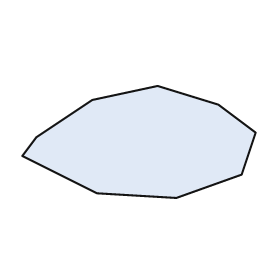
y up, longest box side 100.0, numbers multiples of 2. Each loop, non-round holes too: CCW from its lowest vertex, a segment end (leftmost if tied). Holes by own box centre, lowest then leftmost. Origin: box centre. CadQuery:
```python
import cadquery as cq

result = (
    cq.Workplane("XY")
    .moveTo(16.0, -24.0)
    .lineTo(44.0, -14.0)
    .lineTo(50.0, 4.0)
    .lineTo(34.0, 16.0)
    .lineTo(8.0, 24.0)
    .lineTo(-20.0, 18.0)
    .lineTo(-44.0, 2.0)
    .lineTo(-50.0, -6.0)
    .lineTo(-18.0, -22.0)
    .close()
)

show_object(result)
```